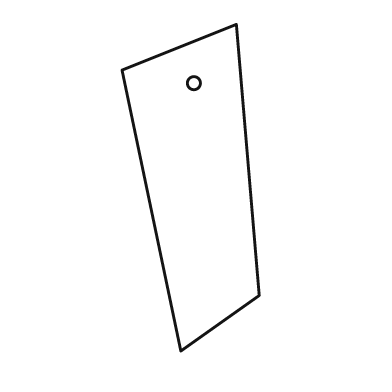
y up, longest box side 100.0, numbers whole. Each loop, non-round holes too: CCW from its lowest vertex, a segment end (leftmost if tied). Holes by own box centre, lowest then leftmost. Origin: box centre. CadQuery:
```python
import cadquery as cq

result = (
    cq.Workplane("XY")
    .moveTo(-3.0, -50.0)
    .lineTo(21.0, -33.0)
    .lineTo(14.0, 50.0)
    .lineTo(-21.0, 36.0)
    .close()
    .moveTo(1.0, 32.0)
    .circle(2.0)
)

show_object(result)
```